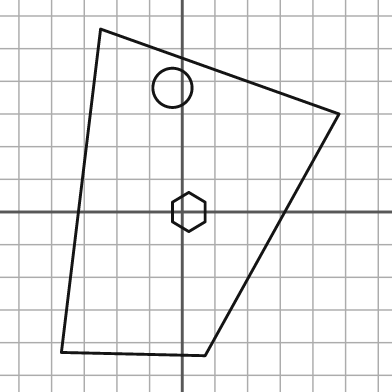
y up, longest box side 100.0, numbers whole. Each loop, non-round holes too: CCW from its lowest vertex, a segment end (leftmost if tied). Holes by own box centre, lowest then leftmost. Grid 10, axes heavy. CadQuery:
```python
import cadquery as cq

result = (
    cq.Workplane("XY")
    .moveTo(7.0, -44.0)
    .lineTo(48.0, 30.0)
    .lineTo(-25.0, 56.0)
    .lineTo(-37.0, -43.0)
    .close()
    .moveTo(2.0, -6.0)
    .lineTo(7.0, -3.0)
    .lineTo(7.0, 3.0)
    .lineTo(2.0, 6.0)
    .lineTo(-3.0, 3.0)
    .lineTo(-3.0, -3.0)
    .close()
    .moveTo(-3.0, 38.0)
    .circle(6.0)
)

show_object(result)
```